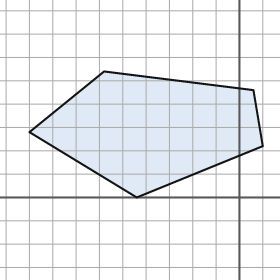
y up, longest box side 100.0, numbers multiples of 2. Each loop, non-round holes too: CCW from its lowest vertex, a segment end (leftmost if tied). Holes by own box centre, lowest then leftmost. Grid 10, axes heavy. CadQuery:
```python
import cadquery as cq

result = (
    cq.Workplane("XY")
    .moveTo(-44.0, 0.0)
    .lineTo(10.0, 22.0)
    .lineTo(6.0, 46.0)
    .lineTo(-58.0, 54.0)
    .lineTo(-90.0, 28.0)
    .close()
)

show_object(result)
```